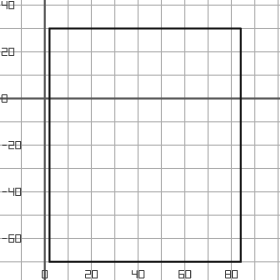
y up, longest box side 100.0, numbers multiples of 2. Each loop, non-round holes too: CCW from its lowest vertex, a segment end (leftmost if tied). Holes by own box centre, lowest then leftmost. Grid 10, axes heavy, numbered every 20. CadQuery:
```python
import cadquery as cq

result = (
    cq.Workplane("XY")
    .moveTo(2.0, -70.0)
    .lineTo(84.0, -70.0)
    .lineTo(84.0, 30.0)
    .lineTo(2.0, 30.0)
    .close()
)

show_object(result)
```